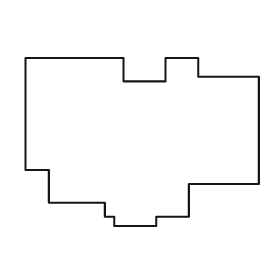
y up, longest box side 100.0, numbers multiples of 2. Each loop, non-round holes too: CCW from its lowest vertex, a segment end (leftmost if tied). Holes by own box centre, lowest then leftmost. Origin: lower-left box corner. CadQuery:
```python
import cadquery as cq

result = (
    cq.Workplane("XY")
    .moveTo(38.0, 0.0)
    .lineTo(56.0, 0.0)
    .lineTo(56.0, 4.0)
    .lineTo(70.0, 4.0)
    .lineTo(70.0, 18.0)
    .lineTo(100.0, 18.0)
    .lineTo(100.0, 64.0)
    .lineTo(74.0, 64.0)
    .lineTo(74.0, 72.0)
    .lineTo(60.0, 72.0)
    .lineTo(60.0, 62.0)
    .lineTo(42.0, 62.0)
    .lineTo(42.0, 72.0)
    .lineTo(0.0, 72.0)
    .lineTo(0.0, 24.0)
    .lineTo(10.0, 24.0)
    .lineTo(10.0, 10.0)
    .lineTo(34.0, 10.0)
    .lineTo(34.0, 4.0)
    .lineTo(38.0, 4.0)
    .close()
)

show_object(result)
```